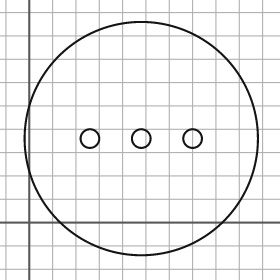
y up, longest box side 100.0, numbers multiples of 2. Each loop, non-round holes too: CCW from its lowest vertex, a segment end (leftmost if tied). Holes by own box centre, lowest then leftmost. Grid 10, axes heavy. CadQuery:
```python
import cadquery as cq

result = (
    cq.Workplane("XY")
    .moveTo(48.0, 36.0)
    .circle(50.0)
    .moveTo(26.0, 36.0)
    .circle(4.0)
    .moveTo(48.0, 36.0)
    .circle(4.0)
    .moveTo(70.0, 36.0)
    .circle(4.0)
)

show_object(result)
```